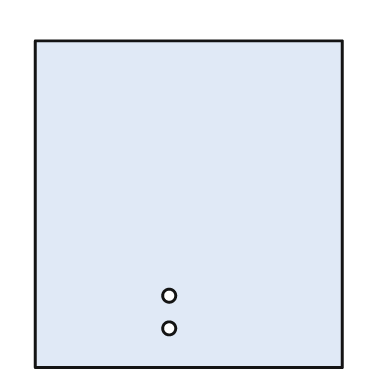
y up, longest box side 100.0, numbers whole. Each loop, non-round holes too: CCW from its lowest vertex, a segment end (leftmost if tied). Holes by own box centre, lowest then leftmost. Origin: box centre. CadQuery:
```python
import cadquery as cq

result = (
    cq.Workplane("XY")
    .moveTo(-47.0, -50.0)
    .lineTo(47.0, -50.0)
    .lineTo(47.0, 50.0)
    .lineTo(-47.0, 50.0)
    .close()
    .moveTo(-6.0, -38.0)
    .circle(2.0)
    .moveTo(-6.0, -28.0)
    .circle(2.0)
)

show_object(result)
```